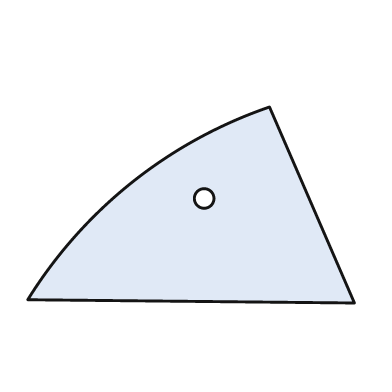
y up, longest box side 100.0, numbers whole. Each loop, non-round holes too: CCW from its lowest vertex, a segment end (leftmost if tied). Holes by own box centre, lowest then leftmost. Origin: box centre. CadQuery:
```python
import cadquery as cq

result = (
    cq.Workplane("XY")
    .moveTo(50.0, -30.0)
    .lineTo(24.0, 30.0)
    .threePointArc((-18.0, 7.0), (-50.0, -29.0))
    .close()
    .moveTo(4.0, 2.0)
    .circle(3.0)
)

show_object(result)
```